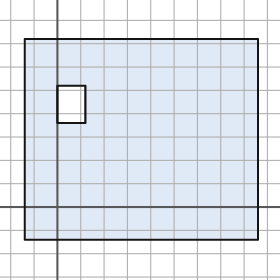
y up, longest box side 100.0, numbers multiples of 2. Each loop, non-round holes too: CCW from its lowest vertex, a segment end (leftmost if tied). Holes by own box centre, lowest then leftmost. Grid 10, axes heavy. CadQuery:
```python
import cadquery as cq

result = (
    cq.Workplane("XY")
    .moveTo(-14.0, -14.0)
    .lineTo(86.0, -14.0)
    .lineTo(86.0, 72.0)
    .lineTo(-14.0, 72.0)
    .close()
    .moveTo(0.0, 36.0)
    .lineTo(12.0, 36.0)
    .lineTo(12.0, 52.0)
    .lineTo(0.0, 52.0)
    .close()
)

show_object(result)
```